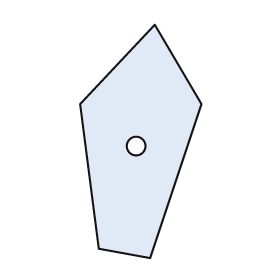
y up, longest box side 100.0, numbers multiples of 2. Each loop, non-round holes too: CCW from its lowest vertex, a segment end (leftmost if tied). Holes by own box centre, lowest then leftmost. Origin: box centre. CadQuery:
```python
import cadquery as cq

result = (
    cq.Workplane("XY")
    .moveTo(4.0, -50.0)
    .lineTo(26.0, 16.0)
    .lineTo(6.0, 50.0)
    .lineTo(-26.0, 16.0)
    .lineTo(-18.0, -46.0)
    .close()
    .moveTo(-2.0, -2.0)
    .circle(4.0)
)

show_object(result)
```